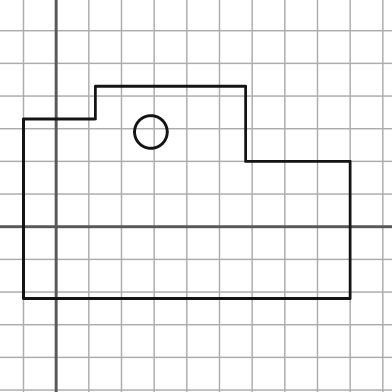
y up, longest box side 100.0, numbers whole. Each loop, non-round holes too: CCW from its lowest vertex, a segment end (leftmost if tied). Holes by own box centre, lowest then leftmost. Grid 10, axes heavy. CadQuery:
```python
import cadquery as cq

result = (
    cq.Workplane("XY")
    .moveTo(-10.0, -22.0)
    .lineTo(90.0, -22.0)
    .lineTo(90.0, 20.0)
    .lineTo(58.0, 20.0)
    .lineTo(58.0, 43.0)
    .lineTo(12.0, 43.0)
    .lineTo(12.0, 33.0)
    .lineTo(-10.0, 33.0)
    .close()
    .moveTo(29.0, 29.0)
    .circle(5.0)
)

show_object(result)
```